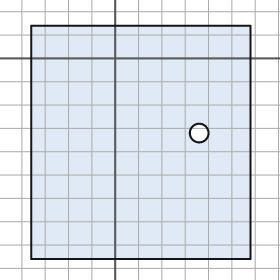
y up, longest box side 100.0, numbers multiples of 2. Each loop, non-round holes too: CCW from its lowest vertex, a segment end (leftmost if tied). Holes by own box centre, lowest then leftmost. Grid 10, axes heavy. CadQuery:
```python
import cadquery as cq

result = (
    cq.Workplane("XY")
    .moveTo(-36.0, -86.0)
    .lineTo(58.0, -86.0)
    .lineTo(58.0, 14.0)
    .lineTo(-36.0, 14.0)
    .close()
    .moveTo(36.0, -32.0)
    .circle(4.0)
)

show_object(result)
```